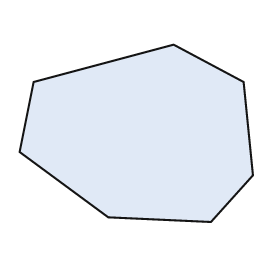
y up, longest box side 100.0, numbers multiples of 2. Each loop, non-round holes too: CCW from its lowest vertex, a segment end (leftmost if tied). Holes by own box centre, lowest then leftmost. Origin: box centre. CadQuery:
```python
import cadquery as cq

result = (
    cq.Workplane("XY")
    .moveTo(32.0, -38.0)
    .lineTo(50.0, -18.0)
    .lineTo(46.0, 22.0)
    .lineTo(16.0, 38.0)
    .lineTo(-44.0, 22.0)
    .lineTo(-50.0, -8.0)
    .lineTo(-12.0, -36.0)
    .close()
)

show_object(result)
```